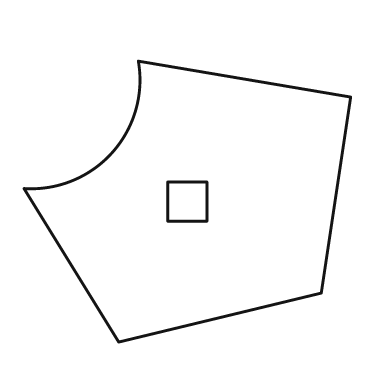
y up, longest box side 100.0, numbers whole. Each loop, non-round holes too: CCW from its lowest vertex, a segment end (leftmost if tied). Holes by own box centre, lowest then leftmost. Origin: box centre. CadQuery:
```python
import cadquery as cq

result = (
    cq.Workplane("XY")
    .moveTo(-21.0, -43.0)
    .lineTo(41.0, -28.0)
    .lineTo(50.0, 32.0)
    .lineTo(-15.0, 43.0)
    .threePointArc((-23.0, 15.0), (-50.0, 4.0))
    .close()
    .moveTo(-6.0, -6.0)
    .lineTo(6.0, -6.0)
    .lineTo(6.0, 6.0)
    .lineTo(-6.0, 6.0)
    .close()
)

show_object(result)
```